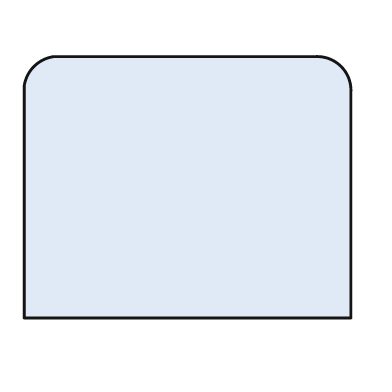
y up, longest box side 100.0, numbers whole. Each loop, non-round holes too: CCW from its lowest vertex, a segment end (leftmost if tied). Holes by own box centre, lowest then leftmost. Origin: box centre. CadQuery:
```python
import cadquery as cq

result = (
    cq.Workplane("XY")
    .moveTo(-50.0, -40.0)
    .lineTo(50.0, -40.0)
    .lineTo(50.0, 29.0)
    .threePointArc((47.0, 37.0), (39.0, 40.0))
    .lineTo(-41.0, 40.0)
    .threePointArc((-47.0, 37.0), (-50.0, 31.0))
    .close()
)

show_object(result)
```